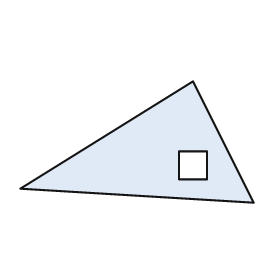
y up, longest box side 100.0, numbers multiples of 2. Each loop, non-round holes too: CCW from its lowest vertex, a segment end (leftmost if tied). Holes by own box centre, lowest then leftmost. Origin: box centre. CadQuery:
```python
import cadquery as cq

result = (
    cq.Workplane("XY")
    .moveTo(50.0, -26.0)
    .lineTo(24.0, 26.0)
    .lineTo(-50.0, -20.0)
    .close()
    .moveTo(18.0, -16.0)
    .lineTo(30.0, -16.0)
    .lineTo(30.0, -4.0)
    .lineTo(18.0, -4.0)
    .close()
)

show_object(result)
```